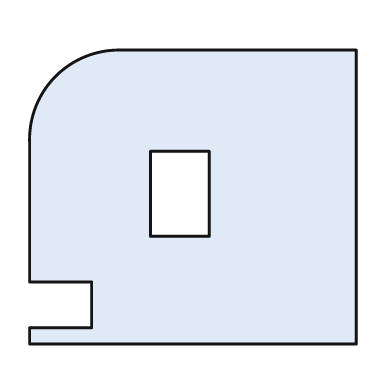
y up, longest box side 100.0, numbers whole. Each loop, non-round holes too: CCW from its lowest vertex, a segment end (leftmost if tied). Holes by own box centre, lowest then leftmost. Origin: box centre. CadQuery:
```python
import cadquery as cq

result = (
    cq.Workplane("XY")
    .moveTo(-50.0, -45.0)
    .lineTo(50.0, -45.0)
    .lineTo(50.0, 45.0)
    .lineTo(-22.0, 45.0)
    .threePointArc((-42.0, 37.0), (-50.0, 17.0))
    .lineTo(-50.0, -26.0)
    .lineTo(-31.0, -26.0)
    .lineTo(-31.0, -40.0)
    .lineTo(-50.0, -40.0)
    .close()
    .moveTo(-13.0, -12.0)
    .lineTo(5.0, -12.0)
    .lineTo(5.0, 14.0)
    .lineTo(-13.0, 14.0)
    .close()
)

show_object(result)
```